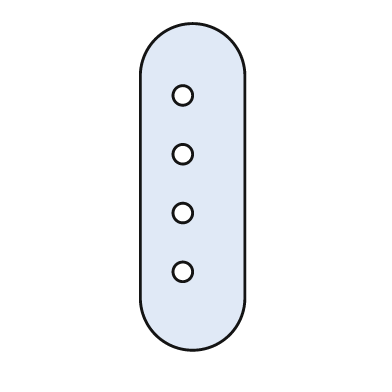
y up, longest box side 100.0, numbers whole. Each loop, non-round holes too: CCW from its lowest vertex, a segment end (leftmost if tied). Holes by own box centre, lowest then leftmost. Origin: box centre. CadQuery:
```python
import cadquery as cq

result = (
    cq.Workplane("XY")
    .moveTo(-16.0, -34.0)
    .threePointArc((0.0, -50.0), (16.0, -34.0))
    .lineTo(16.0, 34.0)
    .threePointArc((0.0, 50.0), (-16.0, 34.0))
    .close()
    .moveTo(-3.0, -26.0)
    .circle(3.0)
    .moveTo(-3.0, -8.0)
    .circle(3.0)
    .moveTo(-3.0, 10.0)
    .circle(3.0)
    .moveTo(-3.0, 28.0)
    .circle(3.0)
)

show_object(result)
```